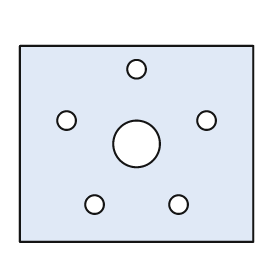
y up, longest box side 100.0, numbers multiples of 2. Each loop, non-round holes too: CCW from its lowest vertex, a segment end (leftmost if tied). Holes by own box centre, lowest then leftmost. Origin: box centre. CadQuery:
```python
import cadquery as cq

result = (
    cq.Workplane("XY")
    .moveTo(-50.0, -42.0)
    .lineTo(50.0, -42.0)
    .lineTo(50.0, 42.0)
    .lineTo(-50.0, 42.0)
    .close()
    .moveTo(-18.0, -26.0)
    .circle(4.0)
    .moveTo(18.0, -26.0)
    .circle(4.0)
    .moveTo(0.0, 0.0)
    .circle(10.0)
    .moveTo(-30.0, 10.0)
    .circle(4.0)
    .moveTo(30.0, 10.0)
    .circle(4.0)
    .moveTo(0.0, 32.0)
    .circle(4.0)
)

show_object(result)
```